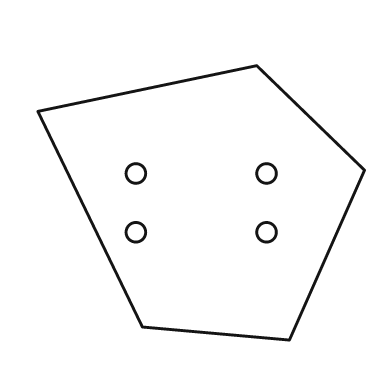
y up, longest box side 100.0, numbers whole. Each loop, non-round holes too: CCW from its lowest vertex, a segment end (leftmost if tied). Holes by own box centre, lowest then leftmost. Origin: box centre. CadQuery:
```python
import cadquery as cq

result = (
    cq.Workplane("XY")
    .moveTo(27.0, -42.0)
    .lineTo(50.0, 10.0)
    .lineTo(17.0, 42.0)
    .lineTo(-50.0, 28.0)
    .lineTo(-18.0, -38.0)
    .close()
    .moveTo(-20.0, -9.0)
    .circle(3.0)
    .moveTo(20.0, -9.0)
    .circle(3.0)
    .moveTo(-20.0, 9.0)
    .circle(3.0)
    .moveTo(20.0, 9.0)
    .circle(3.0)
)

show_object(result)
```